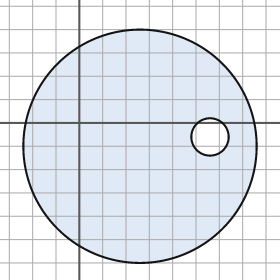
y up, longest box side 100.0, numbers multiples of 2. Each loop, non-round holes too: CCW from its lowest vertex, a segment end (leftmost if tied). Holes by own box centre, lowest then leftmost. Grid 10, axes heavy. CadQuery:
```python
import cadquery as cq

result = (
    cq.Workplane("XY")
    .moveTo(26.0, -10.0)
    .circle(50.0)
    .moveTo(56.0, -6.0)
    .circle(8.0)
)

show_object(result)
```